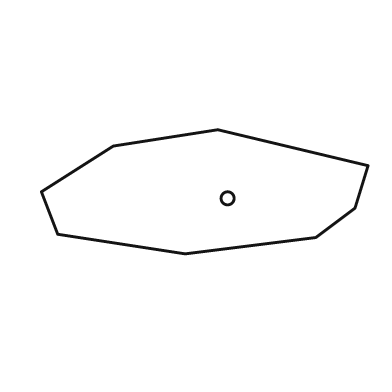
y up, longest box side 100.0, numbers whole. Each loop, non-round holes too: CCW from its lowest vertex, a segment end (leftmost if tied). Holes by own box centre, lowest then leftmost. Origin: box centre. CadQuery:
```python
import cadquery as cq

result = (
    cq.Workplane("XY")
    .moveTo(-6.0, -19.0)
    .lineTo(34.0, -14.0)
    .lineTo(46.0, -5.0)
    .lineTo(50.0, 8.0)
    .lineTo(4.0, 19.0)
    .lineTo(-28.0, 14.0)
    .lineTo(-50.0, 0.0)
    .lineTo(-45.0, -13.0)
    .close()
    .moveTo(7.0, -2.0)
    .circle(2.0)
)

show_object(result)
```